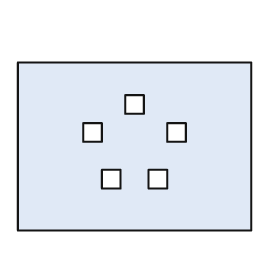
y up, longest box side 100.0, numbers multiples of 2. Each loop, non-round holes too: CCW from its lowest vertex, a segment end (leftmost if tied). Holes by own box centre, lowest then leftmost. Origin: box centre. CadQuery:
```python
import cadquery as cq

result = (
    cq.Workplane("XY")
    .moveTo(-50.0, -36.0)
    .lineTo(50.0, -36.0)
    .lineTo(50.0, 36.0)
    .lineTo(-50.0, 36.0)
    .close()
    .moveTo(-14.0, -18.0)
    .lineTo(-6.0, -18.0)
    .lineTo(-6.0, -10.0)
    .lineTo(-14.0, -10.0)
    .close()
    .moveTo(6.0, -18.0)
    .lineTo(14.0, -18.0)
    .lineTo(14.0, -10.0)
    .lineTo(6.0, -10.0)
    .close()
    .moveTo(-22.0, 2.0)
    .lineTo(-14.0, 2.0)
    .lineTo(-14.0, 10.0)
    .lineTo(-22.0, 10.0)
    .close()
    .moveTo(14.0, 2.0)
    .lineTo(22.0, 2.0)
    .lineTo(22.0, 10.0)
    .lineTo(14.0, 10.0)
    .close()
    .moveTo(-4.0, 14.0)
    .lineTo(4.0, 14.0)
    .lineTo(4.0, 22.0)
    .lineTo(-4.0, 22.0)
    .close()
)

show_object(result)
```